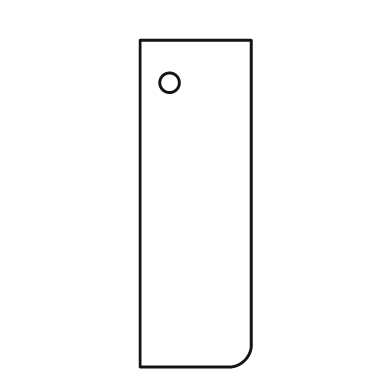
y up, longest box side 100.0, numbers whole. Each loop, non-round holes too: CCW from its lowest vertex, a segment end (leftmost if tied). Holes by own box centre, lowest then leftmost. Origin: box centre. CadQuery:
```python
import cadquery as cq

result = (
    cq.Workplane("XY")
    .moveTo(-17.0, -50.0)
    .lineTo(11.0, -50.0)
    .threePointArc((15.0, -48.0), (17.0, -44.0))
    .lineTo(17.0, 50.0)
    .lineTo(-17.0, 50.0)
    .close()
    .moveTo(-8.0, 37.0)
    .circle(3.0)
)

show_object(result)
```